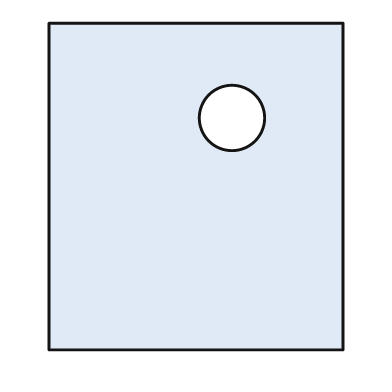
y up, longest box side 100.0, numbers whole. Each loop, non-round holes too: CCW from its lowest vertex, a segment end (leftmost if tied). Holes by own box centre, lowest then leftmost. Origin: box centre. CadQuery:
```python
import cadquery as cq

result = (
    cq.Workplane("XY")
    .moveTo(-45.0, -50.0)
    .lineTo(45.0, -50.0)
    .lineTo(45.0, 50.0)
    .lineTo(-45.0, 50.0)
    .close()
    .moveTo(11.0, 21.0)
    .circle(10.0)
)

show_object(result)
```